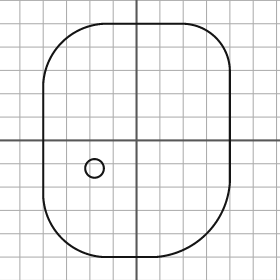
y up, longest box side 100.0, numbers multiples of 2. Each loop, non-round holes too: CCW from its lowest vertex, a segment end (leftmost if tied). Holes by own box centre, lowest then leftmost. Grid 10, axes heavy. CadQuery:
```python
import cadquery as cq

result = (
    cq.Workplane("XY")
    .moveTo(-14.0, -50.0)
    .lineTo(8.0, -50.0)
    .threePointArc((30.0, -40.0), (40.0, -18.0))
    .lineTo(40.0, 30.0)
    .threePointArc((34.0, 44.0), (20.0, 50.0))
    .lineTo(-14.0, 50.0)
    .threePointArc((-32.0, 42.0), (-40.0, 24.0))
    .lineTo(-40.0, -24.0)
    .threePointArc((-32.0, -42.0), (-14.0, -50.0))
    .close()
    .moveTo(-18.0, -12.0)
    .circle(4.0)
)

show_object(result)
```